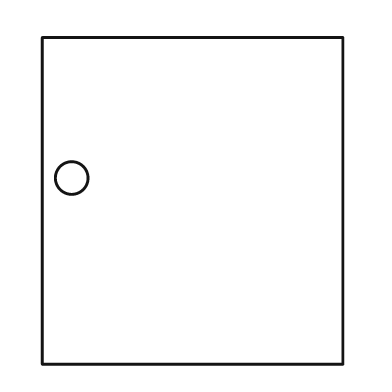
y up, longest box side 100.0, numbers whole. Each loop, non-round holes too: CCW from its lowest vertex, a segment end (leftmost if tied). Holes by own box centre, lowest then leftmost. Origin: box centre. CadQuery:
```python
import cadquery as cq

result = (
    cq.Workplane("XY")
    .moveTo(-46.0, -50.0)
    .lineTo(46.0, -50.0)
    .lineTo(46.0, 50.0)
    .lineTo(-46.0, 50.0)
    .close()
    .moveTo(-37.0, 7.0)
    .circle(5.0)
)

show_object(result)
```